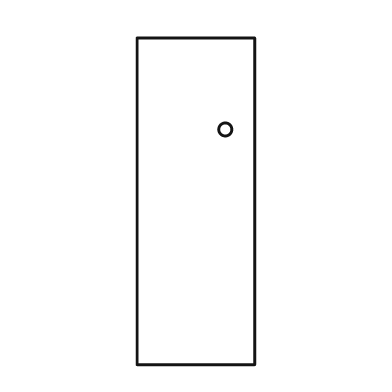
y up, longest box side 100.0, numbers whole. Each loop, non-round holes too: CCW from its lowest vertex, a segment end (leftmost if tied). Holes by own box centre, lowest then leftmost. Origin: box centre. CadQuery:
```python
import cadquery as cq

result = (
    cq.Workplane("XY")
    .moveTo(-18.0, -50.0)
    .lineTo(18.0, -50.0)
    .lineTo(18.0, 50.0)
    .lineTo(-18.0, 50.0)
    .close()
    .moveTo(9.0, 22.0)
    .circle(2.0)
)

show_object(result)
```